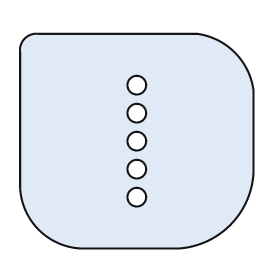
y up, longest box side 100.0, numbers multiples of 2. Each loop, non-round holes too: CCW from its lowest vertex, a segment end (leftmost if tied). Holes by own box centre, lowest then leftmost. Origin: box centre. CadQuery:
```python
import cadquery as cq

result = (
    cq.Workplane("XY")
    .moveTo(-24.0, -46.0)
    .lineTo(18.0, -46.0)
    .threePointArc((40.0, -36.0), (50.0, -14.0))
    .lineTo(50.0, 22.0)
    .threePointArc((42.0, 38.0), (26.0, 46.0))
    .lineTo(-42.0, 46.0)
    .threePointArc((-48.0, 44.0), (-50.0, 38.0))
    .lineTo(-50.0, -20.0)
    .threePointArc((-42.0, -38.0), (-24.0, -46.0))
    .close()
    .moveTo(0.0, -24.0)
    .circle(4.0)
    .moveTo(0.0, -12.0)
    .circle(4.0)
    .moveTo(0.0, 0.0)
    .circle(4.0)
    .moveTo(0.0, 12.0)
    .circle(4.0)
    .moveTo(0.0, 24.0)
    .circle(4.0)
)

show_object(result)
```